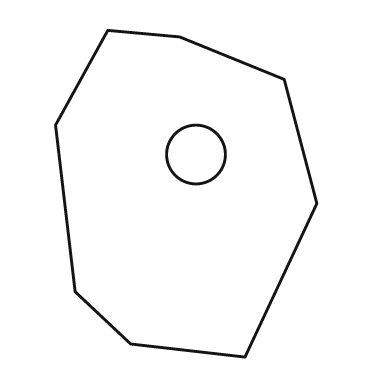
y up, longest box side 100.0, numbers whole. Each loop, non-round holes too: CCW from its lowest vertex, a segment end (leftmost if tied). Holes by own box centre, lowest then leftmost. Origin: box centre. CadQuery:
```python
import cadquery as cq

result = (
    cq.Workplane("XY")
    .moveTo(18.0, -50.0)
    .lineTo(40.0, -3.0)
    .lineTo(30.0, 35.0)
    .lineTo(-2.0, 48.0)
    .lineTo(-24.0, 50.0)
    .lineTo(-40.0, 21.0)
    .lineTo(-34.0, -30.0)
    .lineTo(-17.0, -46.0)
    .close()
    .moveTo(3.0, 12.0)
    .circle(9.0)
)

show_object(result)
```